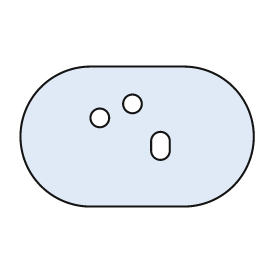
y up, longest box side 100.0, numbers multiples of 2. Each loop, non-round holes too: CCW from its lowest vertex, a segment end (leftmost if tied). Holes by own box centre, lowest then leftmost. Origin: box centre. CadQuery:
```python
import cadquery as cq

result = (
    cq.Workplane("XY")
    .moveTo(-20.0, -30.0)
    .lineTo(20.0, -30.0)
    .threePointArc((50.0, 0.0), (20.0, 30.0))
    .lineTo(-20.0, 30.0)
    .threePointArc((-50.0, 0.0), (-20.0, -30.0))
    .close()
    .moveTo(6.0, -6.0)
    .threePointArc((10.0, -10.0), (14.0, -6.0))
    .lineTo(14.0, -2.0)
    .threePointArc((10.0, 2.0), (6.0, -2.0))
    .close()
    .moveTo(-16.0, 8.0)
    .circle(4.0)
    .moveTo(-2.0, 14.0)
    .circle(4.0)
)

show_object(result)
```